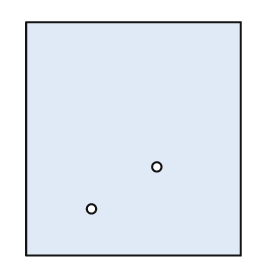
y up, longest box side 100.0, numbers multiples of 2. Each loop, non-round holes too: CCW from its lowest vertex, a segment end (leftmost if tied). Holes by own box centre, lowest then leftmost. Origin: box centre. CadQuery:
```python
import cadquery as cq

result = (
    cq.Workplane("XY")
    .moveTo(-46.0, -50.0)
    .lineTo(46.0, -50.0)
    .lineTo(46.0, 50.0)
    .lineTo(-46.0, 50.0)
    .close()
    .moveTo(-18.0, -30.0)
    .circle(2.0)
    .moveTo(10.0, -12.0)
    .circle(2.0)
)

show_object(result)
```